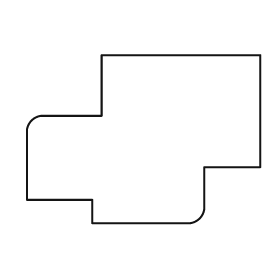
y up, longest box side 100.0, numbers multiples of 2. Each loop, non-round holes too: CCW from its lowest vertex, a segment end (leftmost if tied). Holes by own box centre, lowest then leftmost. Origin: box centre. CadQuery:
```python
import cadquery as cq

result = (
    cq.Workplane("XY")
    .moveTo(-22.0, -36.0)
    .lineTo(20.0, -36.0)
    .threePointArc((24.0, -34.0), (26.0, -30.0))
    .lineTo(26.0, -12.0)
    .lineTo(50.0, -12.0)
    .lineTo(50.0, 36.0)
    .lineTo(-18.0, 36.0)
    .lineTo(-18.0, 10.0)
    .lineTo(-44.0, 10.0)
    .threePointArc((-48.0, 8.0), (-50.0, 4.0))
    .lineTo(-50.0, -26.0)
    .lineTo(-22.0, -26.0)
    .close()
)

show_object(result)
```